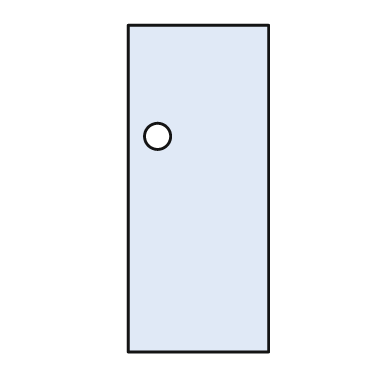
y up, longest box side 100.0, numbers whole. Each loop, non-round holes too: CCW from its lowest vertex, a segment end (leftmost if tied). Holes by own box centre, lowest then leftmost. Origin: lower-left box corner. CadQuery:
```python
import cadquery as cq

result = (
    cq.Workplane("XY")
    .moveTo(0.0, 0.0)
    .lineTo(43.0, 0.0)
    .lineTo(43.0, 100.0)
    .lineTo(0.0, 100.0)
    .close()
    .moveTo(9.0, 66.0)
    .circle(4.0)
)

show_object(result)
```